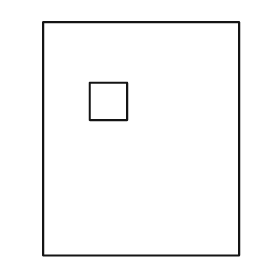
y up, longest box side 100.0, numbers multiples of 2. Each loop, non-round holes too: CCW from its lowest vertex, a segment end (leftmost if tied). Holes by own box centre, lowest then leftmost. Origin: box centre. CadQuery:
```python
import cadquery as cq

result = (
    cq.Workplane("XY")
    .moveTo(-42.0, -50.0)
    .lineTo(42.0, -50.0)
    .lineTo(42.0, 50.0)
    .lineTo(-42.0, 50.0)
    .close()
    .moveTo(-22.0, 8.0)
    .lineTo(-6.0, 8.0)
    .lineTo(-6.0, 24.0)
    .lineTo(-22.0, 24.0)
    .close()
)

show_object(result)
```